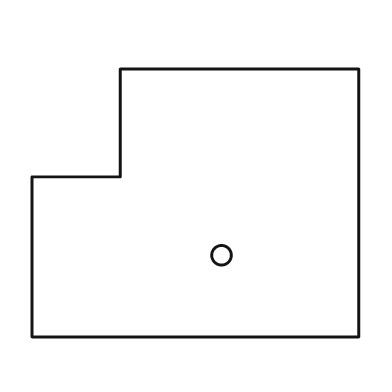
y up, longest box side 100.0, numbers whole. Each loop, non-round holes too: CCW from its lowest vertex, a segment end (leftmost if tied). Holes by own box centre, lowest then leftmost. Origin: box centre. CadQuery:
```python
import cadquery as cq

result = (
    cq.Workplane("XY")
    .moveTo(-50.0, -41.0)
    .lineTo(50.0, -41.0)
    .lineTo(50.0, 41.0)
    .lineTo(-23.0, 41.0)
    .lineTo(-23.0, 8.0)
    .lineTo(-50.0, 8.0)
    .close()
    .moveTo(8.0, -16.0)
    .circle(3.0)
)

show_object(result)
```